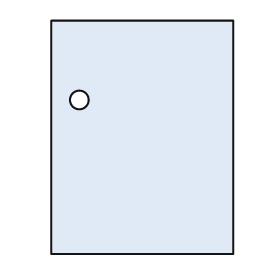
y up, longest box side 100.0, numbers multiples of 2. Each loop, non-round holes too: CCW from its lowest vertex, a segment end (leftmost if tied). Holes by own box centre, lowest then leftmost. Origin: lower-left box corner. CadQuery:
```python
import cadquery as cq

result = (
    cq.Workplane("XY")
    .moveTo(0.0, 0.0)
    .lineTo(78.0, 0.0)
    .lineTo(78.0, 100.0)
    .lineTo(0.0, 100.0)
    .close()
    .moveTo(12.0, 66.0)
    .circle(4.0)
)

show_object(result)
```